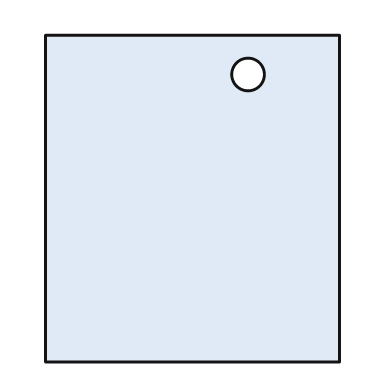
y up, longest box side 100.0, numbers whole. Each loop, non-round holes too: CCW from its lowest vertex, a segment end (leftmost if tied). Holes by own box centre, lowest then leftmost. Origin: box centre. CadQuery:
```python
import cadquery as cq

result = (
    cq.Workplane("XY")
    .moveTo(-45.0, -50.0)
    .lineTo(45.0, -50.0)
    .lineTo(45.0, 50.0)
    .lineTo(-45.0, 50.0)
    .close()
    .moveTo(17.0, 38.0)
    .circle(5.0)
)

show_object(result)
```